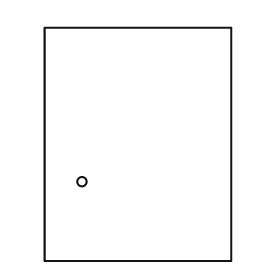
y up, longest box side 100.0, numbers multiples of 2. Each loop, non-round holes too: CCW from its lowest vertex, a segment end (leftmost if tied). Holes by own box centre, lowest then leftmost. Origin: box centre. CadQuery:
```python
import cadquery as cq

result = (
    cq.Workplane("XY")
    .moveTo(-40.0, -50.0)
    .lineTo(40.0, -50.0)
    .lineTo(40.0, 50.0)
    .lineTo(-40.0, 50.0)
    .close()
    .moveTo(-24.0, -16.0)
    .circle(2.0)
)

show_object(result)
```